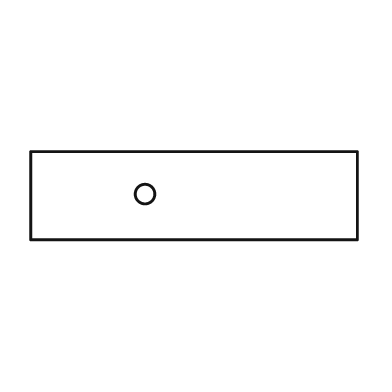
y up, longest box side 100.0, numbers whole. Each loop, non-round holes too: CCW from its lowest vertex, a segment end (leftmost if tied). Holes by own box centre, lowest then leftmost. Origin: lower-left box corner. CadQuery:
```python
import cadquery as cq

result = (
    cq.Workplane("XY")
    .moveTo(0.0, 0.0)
    .lineTo(100.0, 0.0)
    .lineTo(100.0, 27.0)
    .lineTo(0.0, 27.0)
    .close()
    .moveTo(35.0, 14.0)
    .circle(3.0)
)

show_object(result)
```